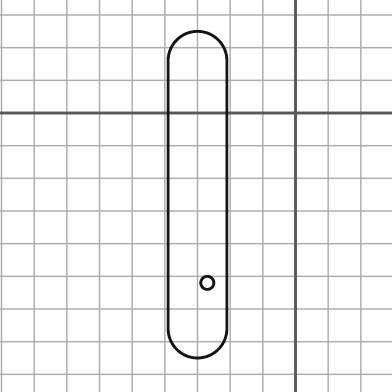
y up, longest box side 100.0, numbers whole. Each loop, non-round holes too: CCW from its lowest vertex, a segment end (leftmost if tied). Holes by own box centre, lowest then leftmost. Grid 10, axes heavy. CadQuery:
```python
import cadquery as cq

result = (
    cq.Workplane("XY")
    .moveTo(-39.0, -66.0)
    .threePointArc((-30.0, -75.0), (-21.0, -66.0))
    .lineTo(-21.0, 16.0)
    .threePointArc((-30.0, 25.0), (-39.0, 16.0))
    .close()
    .moveTo(-27.0, -52.0)
    .circle(2.0)
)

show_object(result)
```